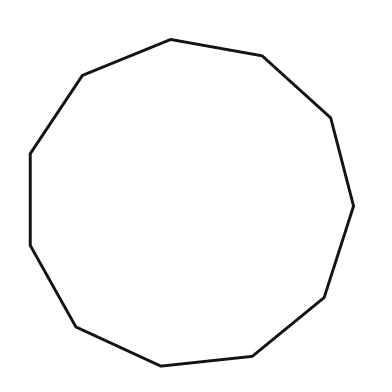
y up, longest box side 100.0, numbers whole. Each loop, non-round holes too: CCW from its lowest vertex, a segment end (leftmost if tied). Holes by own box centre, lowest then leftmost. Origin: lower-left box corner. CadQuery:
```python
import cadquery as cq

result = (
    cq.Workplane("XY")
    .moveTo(40.0, 0.0)
    .lineTo(68.0, 3.0)
    .lineTo(90.0, 21.0)
    .lineTo(99.0, 49.0)
    .lineTo(92.0, 76.0)
    .lineTo(71.0, 95.0)
    .lineTo(43.0, 100.0)
    .lineTo(16.0, 89.0)
    .lineTo(0.0, 65.0)
    .lineTo(0.0, 37.0)
    .lineTo(14.0, 12.0)
    .close()
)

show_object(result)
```